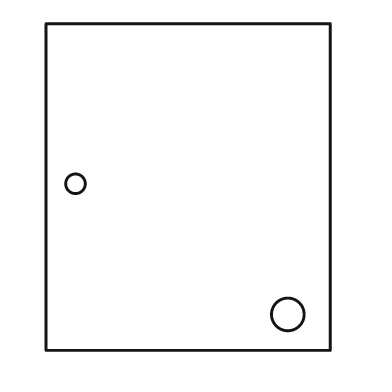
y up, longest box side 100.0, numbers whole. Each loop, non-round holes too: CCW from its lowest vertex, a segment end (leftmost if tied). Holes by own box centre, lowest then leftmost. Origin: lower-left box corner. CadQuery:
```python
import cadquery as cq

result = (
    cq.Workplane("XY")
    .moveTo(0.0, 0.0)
    .lineTo(87.0, 0.0)
    .lineTo(87.0, 100.0)
    .lineTo(0.0, 100.0)
    .close()
    .moveTo(74.0, 11.0)
    .circle(5.0)
    .moveTo(9.0, 51.0)
    .circle(3.0)
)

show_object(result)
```